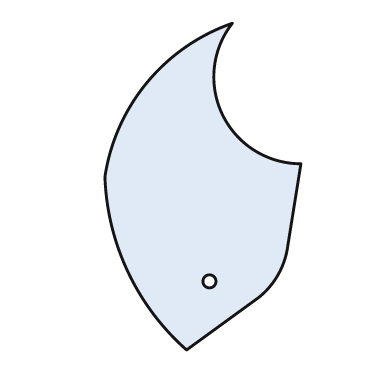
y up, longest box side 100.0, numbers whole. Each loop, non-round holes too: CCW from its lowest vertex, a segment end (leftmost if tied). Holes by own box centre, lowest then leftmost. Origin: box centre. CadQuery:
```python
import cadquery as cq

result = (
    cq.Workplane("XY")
    .moveTo(-5.0, -50.0)
    .lineTo(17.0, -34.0)
    .threePointArc((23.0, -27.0), (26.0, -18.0))
    .lineTo(30.0, 7.0)
    .threePointArc((6.0, 22.0), (9.0, 50.0))
    .threePointArc((-17.0, 32.0), (-30.0, 3.0))
    .threePointArc((-23.0, -26.0), (-5.0, -50.0))
    .close()
    .moveTo(2.0, -29.0)
    .circle(2.0)
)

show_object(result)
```